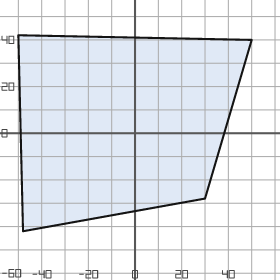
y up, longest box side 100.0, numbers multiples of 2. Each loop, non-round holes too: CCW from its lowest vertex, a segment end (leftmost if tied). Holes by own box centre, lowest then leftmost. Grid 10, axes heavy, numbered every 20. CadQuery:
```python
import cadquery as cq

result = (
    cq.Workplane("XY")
    .moveTo(-48.0, -42.0)
    .lineTo(30.0, -28.0)
    .lineTo(50.0, 40.0)
    .lineTo(-50.0, 42.0)
    .close()
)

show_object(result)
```